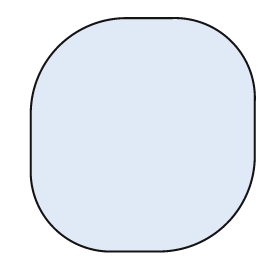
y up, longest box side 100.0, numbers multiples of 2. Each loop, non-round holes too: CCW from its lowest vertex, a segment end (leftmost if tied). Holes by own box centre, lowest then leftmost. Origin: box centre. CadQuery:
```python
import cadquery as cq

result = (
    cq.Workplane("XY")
    .moveTo(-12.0, -50.0)
    .lineTo(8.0, -50.0)
    .threePointArc((36.0, -38.0), (48.0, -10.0))
    .lineTo(48.0, 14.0)
    .threePointArc((38.0, 40.0), (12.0, 50.0))
    .lineTo(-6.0, 50.0)
    .threePointArc((-36.0, 38.0), (-48.0, 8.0))
    .lineTo(-48.0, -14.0)
    .threePointArc((-38.0, -40.0), (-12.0, -50.0))
    .close()
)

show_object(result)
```